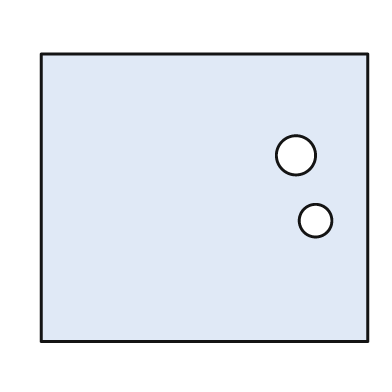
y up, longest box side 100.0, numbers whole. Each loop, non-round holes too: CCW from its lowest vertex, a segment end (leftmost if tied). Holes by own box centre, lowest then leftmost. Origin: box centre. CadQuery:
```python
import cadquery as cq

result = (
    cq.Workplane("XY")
    .moveTo(-50.0, -44.0)
    .lineTo(50.0, -44.0)
    .lineTo(50.0, 44.0)
    .lineTo(-50.0, 44.0)
    .close()
    .moveTo(34.0, -7.0)
    .circle(5.0)
    .moveTo(28.0, 13.0)
    .circle(6.0)
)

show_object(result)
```